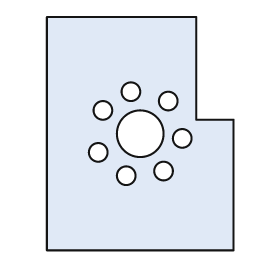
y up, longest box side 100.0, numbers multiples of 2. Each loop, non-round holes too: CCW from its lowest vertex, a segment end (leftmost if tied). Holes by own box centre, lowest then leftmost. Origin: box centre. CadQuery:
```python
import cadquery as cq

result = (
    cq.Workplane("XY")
    .moveTo(-40.0, -50.0)
    .lineTo(40.0, -50.0)
    .lineTo(40.0, 6.0)
    .lineTo(24.0, 6.0)
    .lineTo(24.0, 50.0)
    .lineTo(-40.0, 50.0)
    .close()
    .moveTo(-6.0, -18.0)
    .circle(4.0)
    .moveTo(10.0, -16.0)
    .circle(4.0)
    .moveTo(-18.0, -8.0)
    .circle(4.0)
    .moveTo(18.0, -2.0)
    .circle(4.0)
    .moveTo(0.0, 0.0)
    .circle(10.0)
    .moveTo(-16.0, 10.0)
    .circle(4.0)
    .moveTo(12.0, 14.0)
    .circle(4.0)
    .moveTo(-4.0, 18.0)
    .circle(4.0)
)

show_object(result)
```